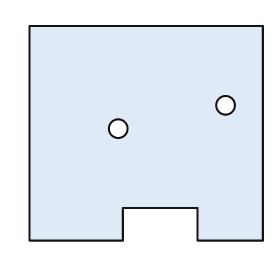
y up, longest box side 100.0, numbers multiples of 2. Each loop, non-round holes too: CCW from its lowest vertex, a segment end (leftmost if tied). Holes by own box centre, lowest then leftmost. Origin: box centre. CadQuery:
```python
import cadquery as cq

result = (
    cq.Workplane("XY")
    .moveTo(-50.0, -46.0)
    .lineTo(-10.0, -46.0)
    .lineTo(-10.0, -32.0)
    .lineTo(22.0, -32.0)
    .lineTo(22.0, -46.0)
    .lineTo(50.0, -46.0)
    .lineTo(50.0, 46.0)
    .lineTo(-50.0, 46.0)
    .close()
    .moveTo(-12.0, 2.0)
    .circle(4.0)
    .moveTo(34.0, 12.0)
    .circle(4.0)
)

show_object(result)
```